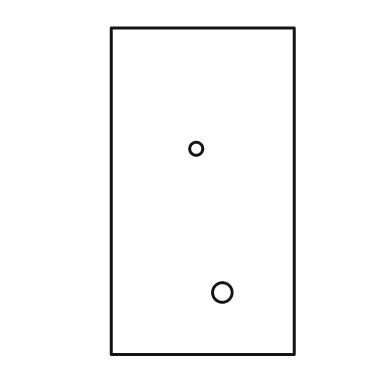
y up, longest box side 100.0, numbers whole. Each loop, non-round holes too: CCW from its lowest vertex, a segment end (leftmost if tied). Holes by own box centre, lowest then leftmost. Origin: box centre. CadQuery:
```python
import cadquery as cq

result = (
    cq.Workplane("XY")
    .moveTo(-28.0, -50.0)
    .lineTo(28.0, -50.0)
    .lineTo(28.0, 50.0)
    .lineTo(-28.0, 50.0)
    .close()
    .moveTo(6.0, -31.0)
    .circle(3.0)
    .moveTo(-2.0, 13.0)
    .circle(2.0)
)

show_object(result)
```